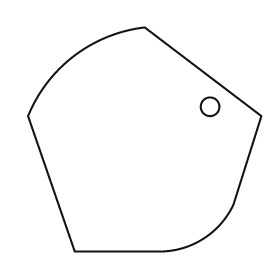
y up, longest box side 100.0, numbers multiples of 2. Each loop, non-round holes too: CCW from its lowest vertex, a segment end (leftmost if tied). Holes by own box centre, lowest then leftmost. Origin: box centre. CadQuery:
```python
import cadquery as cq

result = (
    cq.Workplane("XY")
    .moveTo(-30.0, -48.0)
    .lineTo(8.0, -48.0)
    .threePointArc((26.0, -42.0), (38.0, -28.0))
    .lineTo(50.0, 10.0)
    .lineTo(0.0, 48.0)
    .threePointArc((-30.0, 36.0), (-50.0, 10.0))
    .close()
    .moveTo(28.0, 14.0)
    .circle(4.0)
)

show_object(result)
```